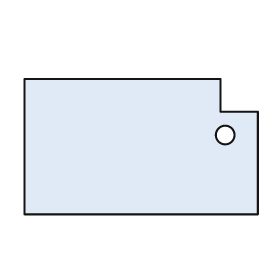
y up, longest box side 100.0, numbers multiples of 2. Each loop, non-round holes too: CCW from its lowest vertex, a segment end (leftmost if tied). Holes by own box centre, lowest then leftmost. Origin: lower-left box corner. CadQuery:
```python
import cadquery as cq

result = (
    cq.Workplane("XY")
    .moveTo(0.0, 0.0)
    .lineTo(100.0, 0.0)
    .lineTo(100.0, 44.0)
    .lineTo(84.0, 44.0)
    .lineTo(84.0, 58.0)
    .lineTo(0.0, 58.0)
    .close()
    .moveTo(86.0, 34.0)
    .circle(4.0)
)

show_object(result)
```